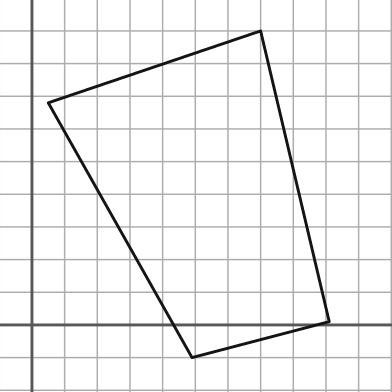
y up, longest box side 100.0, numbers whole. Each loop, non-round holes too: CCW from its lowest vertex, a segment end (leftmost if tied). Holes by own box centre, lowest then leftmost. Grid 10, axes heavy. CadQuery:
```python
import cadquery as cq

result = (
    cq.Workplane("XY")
    .moveTo(49.0, -10.0)
    .lineTo(91.0, 1.0)
    .lineTo(70.0, 90.0)
    .lineTo(5.0, 68.0)
    .close()
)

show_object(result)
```